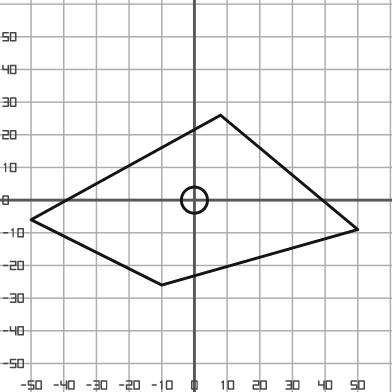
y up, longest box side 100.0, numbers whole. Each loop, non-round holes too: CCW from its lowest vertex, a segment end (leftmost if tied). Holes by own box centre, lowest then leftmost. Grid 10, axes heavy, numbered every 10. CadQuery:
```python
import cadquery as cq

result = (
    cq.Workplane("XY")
    .moveTo(-10.0, -26.0)
    .lineTo(50.0, -9.0)
    .lineTo(8.0, 26.0)
    .lineTo(-50.0, -6.0)
    .close()
    .moveTo(0.0, 0.0)
    .circle(4.0)
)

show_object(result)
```